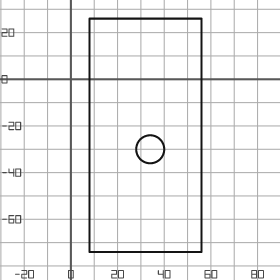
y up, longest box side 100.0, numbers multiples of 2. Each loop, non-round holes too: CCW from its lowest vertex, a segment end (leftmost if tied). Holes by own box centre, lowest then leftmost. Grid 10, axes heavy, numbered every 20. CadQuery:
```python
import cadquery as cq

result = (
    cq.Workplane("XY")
    .moveTo(8.0, -74.0)
    .lineTo(56.0, -74.0)
    .lineTo(56.0, 26.0)
    .lineTo(8.0, 26.0)
    .close()
    .moveTo(34.0, -30.0)
    .circle(6.0)
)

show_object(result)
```